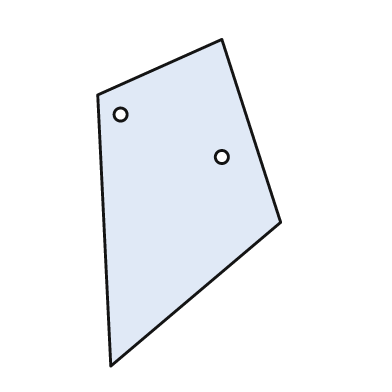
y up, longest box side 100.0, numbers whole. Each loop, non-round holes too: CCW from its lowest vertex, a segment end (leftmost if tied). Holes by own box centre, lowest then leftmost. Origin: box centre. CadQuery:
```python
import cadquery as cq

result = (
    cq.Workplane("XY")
    .moveTo(-24.0, -50.0)
    .lineTo(28.0, -6.0)
    .lineTo(10.0, 50.0)
    .lineTo(-28.0, 33.0)
    .close()
    .moveTo(10.0, 14.0)
    .circle(2.0)
    .moveTo(-21.0, 27.0)
    .circle(2.0)
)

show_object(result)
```